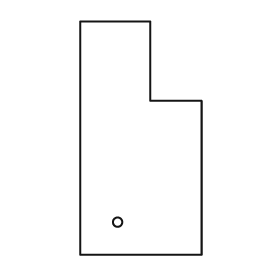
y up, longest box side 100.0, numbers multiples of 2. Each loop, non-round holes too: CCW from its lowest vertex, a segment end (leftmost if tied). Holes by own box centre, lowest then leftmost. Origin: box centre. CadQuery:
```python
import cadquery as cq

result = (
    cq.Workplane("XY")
    .moveTo(-26.0, -50.0)
    .lineTo(26.0, -50.0)
    .lineTo(26.0, 16.0)
    .lineTo(4.0, 16.0)
    .lineTo(4.0, 50.0)
    .lineTo(-26.0, 50.0)
    .close()
    .moveTo(-10.0, -36.0)
    .circle(2.0)
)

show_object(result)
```